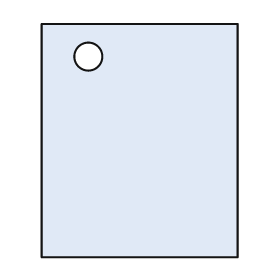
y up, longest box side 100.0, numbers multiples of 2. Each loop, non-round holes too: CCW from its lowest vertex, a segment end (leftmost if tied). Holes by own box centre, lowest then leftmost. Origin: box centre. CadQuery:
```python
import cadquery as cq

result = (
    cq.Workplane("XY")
    .moveTo(-42.0, -50.0)
    .lineTo(42.0, -50.0)
    .lineTo(42.0, 50.0)
    .lineTo(-42.0, 50.0)
    .close()
    .moveTo(-22.0, 36.0)
    .circle(6.0)
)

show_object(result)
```